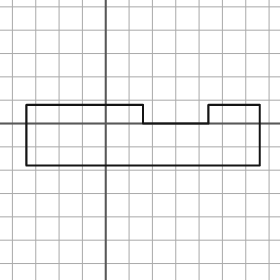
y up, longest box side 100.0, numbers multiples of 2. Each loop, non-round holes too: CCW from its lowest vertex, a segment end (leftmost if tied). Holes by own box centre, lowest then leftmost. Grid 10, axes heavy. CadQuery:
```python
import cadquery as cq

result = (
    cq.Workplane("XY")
    .moveTo(-34.0, -18.0)
    .lineTo(66.0, -18.0)
    .lineTo(66.0, 8.0)
    .lineTo(44.0, 8.0)
    .lineTo(44.0, 0.0)
    .lineTo(16.0, 0.0)
    .lineTo(16.0, 8.0)
    .lineTo(-34.0, 8.0)
    .close()
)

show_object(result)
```